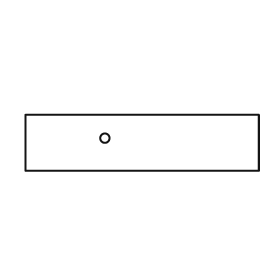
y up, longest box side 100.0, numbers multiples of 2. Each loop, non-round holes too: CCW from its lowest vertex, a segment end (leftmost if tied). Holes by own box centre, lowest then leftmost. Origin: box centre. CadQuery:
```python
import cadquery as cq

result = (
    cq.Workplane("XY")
    .moveTo(-50.0, -12.0)
    .lineTo(50.0, -12.0)
    .lineTo(50.0, 12.0)
    .lineTo(-50.0, 12.0)
    .close()
    .moveTo(-16.0, 2.0)
    .circle(2.0)
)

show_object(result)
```